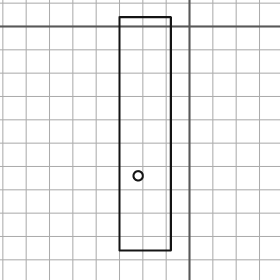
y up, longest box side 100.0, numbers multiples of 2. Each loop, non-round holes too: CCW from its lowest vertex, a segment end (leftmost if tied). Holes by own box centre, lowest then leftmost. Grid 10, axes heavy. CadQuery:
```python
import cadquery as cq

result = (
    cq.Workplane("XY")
    .moveTo(-30.0, -96.0)
    .lineTo(-8.0, -96.0)
    .lineTo(-8.0, 4.0)
    .lineTo(-30.0, 4.0)
    .close()
    .moveTo(-22.0, -64.0)
    .circle(2.0)
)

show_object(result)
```